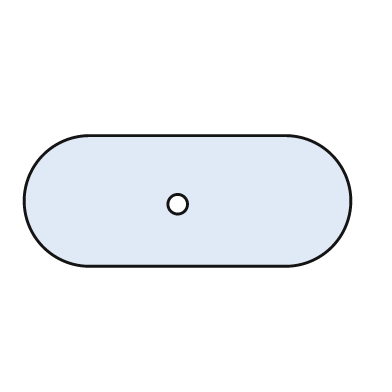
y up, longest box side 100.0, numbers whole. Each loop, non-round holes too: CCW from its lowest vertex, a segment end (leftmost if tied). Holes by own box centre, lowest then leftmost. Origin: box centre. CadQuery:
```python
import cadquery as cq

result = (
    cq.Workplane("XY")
    .moveTo(-30.0, -20.0)
    .lineTo(30.0, -20.0)
    .threePointArc((50.0, 0.0), (30.0, 20.0))
    .lineTo(-30.0, 20.0)
    .threePointArc((-50.0, 0.0), (-30.0, -20.0))
    .close()
    .moveTo(-3.0, -1.0)
    .circle(3.0)
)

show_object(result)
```